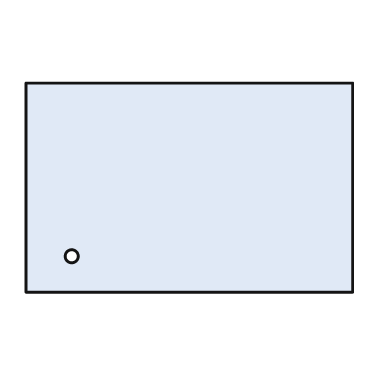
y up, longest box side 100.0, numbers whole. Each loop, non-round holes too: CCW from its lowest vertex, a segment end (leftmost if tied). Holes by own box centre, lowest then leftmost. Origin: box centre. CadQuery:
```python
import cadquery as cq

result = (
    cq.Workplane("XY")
    .moveTo(-50.0, -32.0)
    .lineTo(50.0, -32.0)
    .lineTo(50.0, 32.0)
    .lineTo(-50.0, 32.0)
    .close()
    .moveTo(-36.0, -21.0)
    .circle(2.0)
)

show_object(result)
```